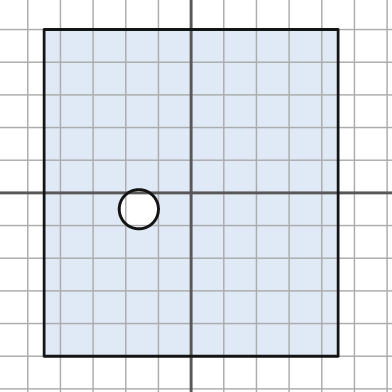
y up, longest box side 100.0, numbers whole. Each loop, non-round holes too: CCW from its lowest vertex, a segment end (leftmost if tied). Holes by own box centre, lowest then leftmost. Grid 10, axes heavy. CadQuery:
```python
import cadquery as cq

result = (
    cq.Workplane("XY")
    .moveTo(-45.0, -50.0)
    .lineTo(45.0, -50.0)
    .lineTo(45.0, 50.0)
    .lineTo(-45.0, 50.0)
    .close()
    .moveTo(-16.0, -5.0)
    .circle(6.0)
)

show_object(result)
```